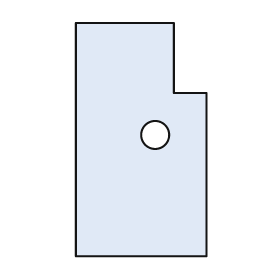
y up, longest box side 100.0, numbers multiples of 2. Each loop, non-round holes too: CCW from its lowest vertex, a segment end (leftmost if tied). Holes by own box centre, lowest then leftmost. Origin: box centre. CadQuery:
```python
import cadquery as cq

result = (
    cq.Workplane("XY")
    .moveTo(-28.0, -50.0)
    .lineTo(28.0, -50.0)
    .lineTo(28.0, 20.0)
    .lineTo(14.0, 20.0)
    .lineTo(14.0, 50.0)
    .lineTo(-28.0, 50.0)
    .close()
    .moveTo(6.0, 2.0)
    .circle(6.0)
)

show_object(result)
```